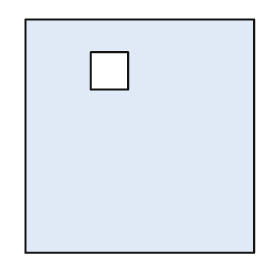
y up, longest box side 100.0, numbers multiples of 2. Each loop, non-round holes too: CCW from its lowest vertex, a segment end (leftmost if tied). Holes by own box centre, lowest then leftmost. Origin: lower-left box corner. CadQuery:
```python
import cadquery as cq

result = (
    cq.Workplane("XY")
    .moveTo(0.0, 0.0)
    .lineTo(98.0, 0.0)
    .lineTo(98.0, 100.0)
    .lineTo(0.0, 100.0)
    .close()
    .moveTo(28.0, 70.0)
    .lineTo(44.0, 70.0)
    .lineTo(44.0, 86.0)
    .lineTo(28.0, 86.0)
    .close()
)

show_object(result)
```